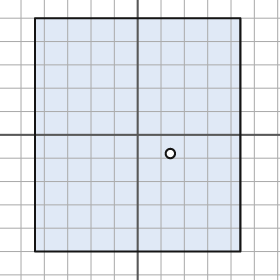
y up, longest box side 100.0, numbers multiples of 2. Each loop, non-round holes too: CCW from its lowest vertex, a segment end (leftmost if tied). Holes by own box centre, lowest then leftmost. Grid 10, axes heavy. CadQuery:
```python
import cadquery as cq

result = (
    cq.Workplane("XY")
    .moveTo(-44.0, -50.0)
    .lineTo(44.0, -50.0)
    .lineTo(44.0, 50.0)
    .lineTo(-44.0, 50.0)
    .close()
    .moveTo(14.0, -8.0)
    .circle(2.0)
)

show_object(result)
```